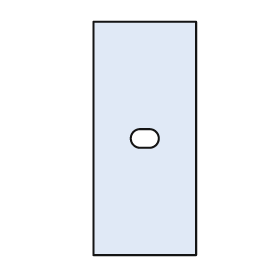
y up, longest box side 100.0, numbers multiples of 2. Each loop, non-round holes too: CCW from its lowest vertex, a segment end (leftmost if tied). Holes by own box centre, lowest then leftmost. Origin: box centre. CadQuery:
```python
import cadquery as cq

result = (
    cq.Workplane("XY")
    .moveTo(-22.0, -50.0)
    .lineTo(22.0, -50.0)
    .lineTo(22.0, 50.0)
    .lineTo(-22.0, 50.0)
    .close()
    .moveTo(-2.0, -4.0)
    .lineTo(2.0, -4.0)
    .threePointArc((6.0, 0.0), (2.0, 4.0))
    .lineTo(-2.0, 4.0)
    .threePointArc((-6.0, 0.0), (-2.0, -4.0))
    .close()
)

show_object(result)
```